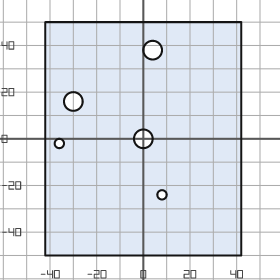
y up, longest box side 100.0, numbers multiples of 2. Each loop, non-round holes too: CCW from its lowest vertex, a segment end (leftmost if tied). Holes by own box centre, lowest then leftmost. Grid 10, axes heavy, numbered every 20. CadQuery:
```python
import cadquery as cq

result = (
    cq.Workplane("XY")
    .moveTo(-42.0, -50.0)
    .lineTo(42.0, -50.0)
    .lineTo(42.0, 50.0)
    .lineTo(-42.0, 50.0)
    .close()
    .moveTo(8.0, -24.0)
    .circle(2.0)
    .moveTo(-36.0, -2.0)
    .circle(2.0)
    .moveTo(0.0, 0.0)
    .circle(4.0)
    .moveTo(-30.0, 16.0)
    .circle(4.0)
    .moveTo(4.0, 38.0)
    .circle(4.0)
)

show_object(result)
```